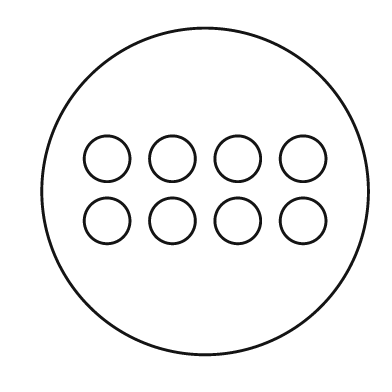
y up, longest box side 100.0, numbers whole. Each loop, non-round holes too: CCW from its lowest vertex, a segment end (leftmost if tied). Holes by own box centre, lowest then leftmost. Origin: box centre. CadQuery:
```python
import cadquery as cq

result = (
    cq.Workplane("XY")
    .moveTo(0.0, 0.0)
    .circle(50.0)
    .moveTo(-30.0, -9.0)
    .circle(7.0)
    .moveTo(-10.0, -9.0)
    .circle(7.0)
    .moveTo(10.0, -9.0)
    .circle(7.0)
    .moveTo(30.0, -9.0)
    .circle(7.0)
    .moveTo(-30.0, 10.0)
    .circle(7.0)
    .moveTo(-10.0, 10.0)
    .circle(7.0)
    .moveTo(10.0, 10.0)
    .circle(7.0)
    .moveTo(30.0, 10.0)
    .circle(7.0)
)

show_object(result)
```